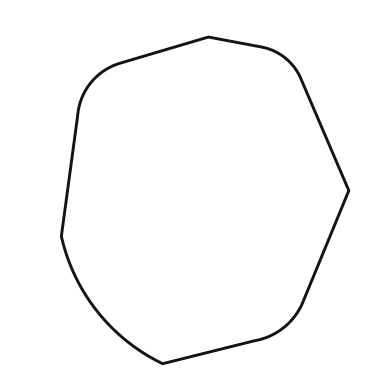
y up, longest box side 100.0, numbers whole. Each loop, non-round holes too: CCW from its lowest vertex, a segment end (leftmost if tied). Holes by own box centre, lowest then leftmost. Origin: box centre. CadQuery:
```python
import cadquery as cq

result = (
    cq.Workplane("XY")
    .moveTo(-13.0, -50.0)
    .lineTo(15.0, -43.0)
    .threePointArc((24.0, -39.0), (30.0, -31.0))
    .lineTo(44.0, 3.0)
    .lineTo(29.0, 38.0)
    .threePointArc((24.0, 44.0), (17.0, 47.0))
    .lineTo(1.0, 50.0)
    .lineTo(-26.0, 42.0)
    .threePointArc((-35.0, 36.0), (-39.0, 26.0))
    .lineTo(-44.0, -11.0)
    .threePointArc((-33.0, -34.0), (-13.0, -50.0))
    .close()
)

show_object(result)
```